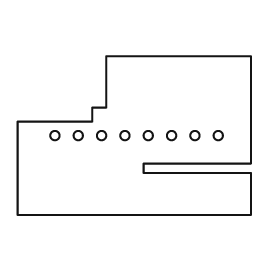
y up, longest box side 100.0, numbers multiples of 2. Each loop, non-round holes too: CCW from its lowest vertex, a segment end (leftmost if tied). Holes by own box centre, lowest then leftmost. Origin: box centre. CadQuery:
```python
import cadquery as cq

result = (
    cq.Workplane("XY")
    .moveTo(-50.0, -34.0)
    .lineTo(50.0, -34.0)
    .lineTo(50.0, -16.0)
    .lineTo(4.0, -16.0)
    .lineTo(4.0, -12.0)
    .lineTo(50.0, -12.0)
    .lineTo(50.0, 34.0)
    .lineTo(-12.0, 34.0)
    .lineTo(-12.0, 12.0)
    .lineTo(-18.0, 12.0)
    .lineTo(-18.0, 6.0)
    .lineTo(-50.0, 6.0)
    .close()
    .moveTo(-34.0, 0.0)
    .circle(2.0)
    .moveTo(-24.0, 0.0)
    .circle(2.0)
    .moveTo(-14.0, 0.0)
    .circle(2.0)
    .moveTo(-4.0, 0.0)
    .circle(2.0)
    .moveTo(6.0, 0.0)
    .circle(2.0)
    .moveTo(16.0, 0.0)
    .circle(2.0)
    .moveTo(26.0, 0.0)
    .circle(2.0)
    .moveTo(36.0, 0.0)
    .circle(2.0)
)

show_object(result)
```